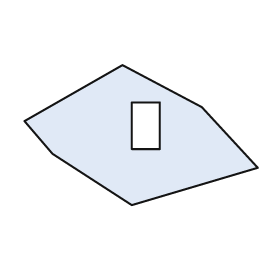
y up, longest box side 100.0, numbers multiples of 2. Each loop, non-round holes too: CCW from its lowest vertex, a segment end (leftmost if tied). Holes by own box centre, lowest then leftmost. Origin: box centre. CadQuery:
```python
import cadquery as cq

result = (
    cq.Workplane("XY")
    .moveTo(-4.0, -30.0)
    .lineTo(50.0, -14.0)
    .lineTo(26.0, 12.0)
    .lineTo(-8.0, 30.0)
    .lineTo(-50.0, 6.0)
    .lineTo(-38.0, -8.0)
    .close()
    .moveTo(-4.0, -6.0)
    .lineTo(8.0, -6.0)
    .lineTo(8.0, 14.0)
    .lineTo(-4.0, 14.0)
    .close()
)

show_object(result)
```